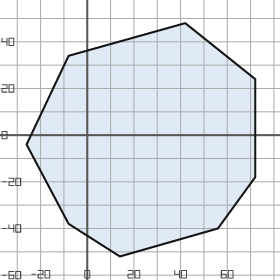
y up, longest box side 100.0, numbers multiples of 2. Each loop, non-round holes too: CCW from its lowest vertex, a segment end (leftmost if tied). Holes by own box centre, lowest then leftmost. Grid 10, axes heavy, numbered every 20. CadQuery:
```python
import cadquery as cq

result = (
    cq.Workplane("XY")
    .moveTo(14.0, -52.0)
    .lineTo(56.0, -40.0)
    .lineTo(72.0, -18.0)
    .lineTo(72.0, 24.0)
    .lineTo(42.0, 48.0)
    .lineTo(-8.0, 34.0)
    .lineTo(-26.0, -4.0)
    .lineTo(-8.0, -38.0)
    .close()
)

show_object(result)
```